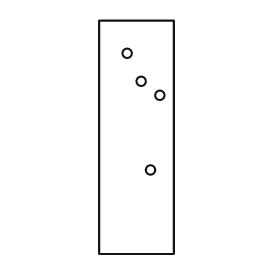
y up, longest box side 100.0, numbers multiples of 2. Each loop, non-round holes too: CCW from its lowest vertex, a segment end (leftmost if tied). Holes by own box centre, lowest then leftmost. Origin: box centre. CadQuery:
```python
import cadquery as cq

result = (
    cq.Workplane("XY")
    .moveTo(-16.0, -50.0)
    .lineTo(16.0, -50.0)
    .lineTo(16.0, 50.0)
    .lineTo(-16.0, 50.0)
    .close()
    .moveTo(6.0, -14.0)
    .circle(2.0)
    .moveTo(10.0, 18.0)
    .circle(2.0)
    .moveTo(2.0, 24.0)
    .circle(2.0)
    .moveTo(-4.0, 36.0)
    .circle(2.0)
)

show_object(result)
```